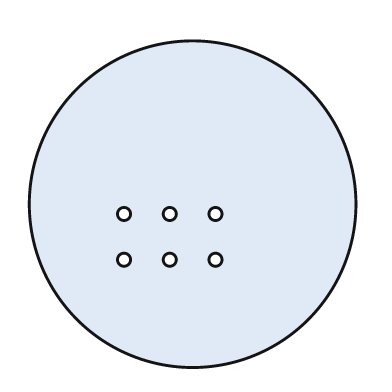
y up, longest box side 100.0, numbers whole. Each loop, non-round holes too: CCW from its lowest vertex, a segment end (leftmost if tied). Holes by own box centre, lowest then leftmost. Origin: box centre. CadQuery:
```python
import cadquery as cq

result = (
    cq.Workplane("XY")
    .moveTo(0.0, 0.0)
    .circle(50.0)
    .moveTo(-21.0, -17.0)
    .circle(2.0)
    .moveTo(-7.0, -17.0)
    .circle(2.0)
    .moveTo(7.0, -17.0)
    .circle(2.0)
    .moveTo(-21.0, -3.0)
    .circle(2.0)
    .moveTo(-7.0, -3.0)
    .circle(2.0)
    .moveTo(7.0, -3.0)
    .circle(2.0)
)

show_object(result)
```